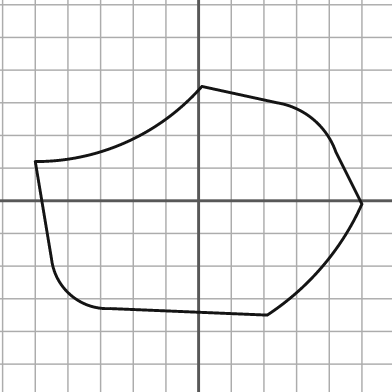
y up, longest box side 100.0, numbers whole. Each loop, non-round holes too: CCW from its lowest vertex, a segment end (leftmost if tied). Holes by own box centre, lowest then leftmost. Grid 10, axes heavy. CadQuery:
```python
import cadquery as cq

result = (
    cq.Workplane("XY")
    .moveTo(21.0, -35.0)
    .threePointArc((38.0, -20.0), (50.0, -1.0))
    .lineTo(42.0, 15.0)
    .threePointArc((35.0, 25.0), (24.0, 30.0))
    .lineTo(1.0, 35.0)
    .threePointArc((-22.0, 18.0), (-50.0, 12.0))
    .lineTo(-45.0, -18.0)
    .threePointArc((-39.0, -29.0), (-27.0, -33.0))
    .close()
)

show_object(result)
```